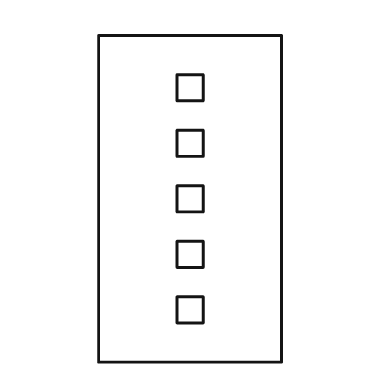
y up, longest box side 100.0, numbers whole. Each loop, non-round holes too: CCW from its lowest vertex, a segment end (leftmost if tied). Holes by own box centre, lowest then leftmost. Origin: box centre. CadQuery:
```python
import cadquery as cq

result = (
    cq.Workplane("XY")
    .moveTo(-28.0, -50.0)
    .lineTo(28.0, -50.0)
    .lineTo(28.0, 50.0)
    .lineTo(-28.0, 50.0)
    .close()
    .moveTo(-4.0, -38.0)
    .lineTo(4.0, -38.0)
    .lineTo(4.0, -30.0)
    .lineTo(-4.0, -30.0)
    .close()
    .moveTo(-4.0, -21.0)
    .lineTo(4.0, -21.0)
    .lineTo(4.0, -13.0)
    .lineTo(-4.0, -13.0)
    .close()
    .moveTo(-4.0, -4.0)
    .lineTo(4.0, -4.0)
    .lineTo(4.0, 4.0)
    .lineTo(-4.0, 4.0)
    .close()
    .moveTo(-4.0, 13.0)
    .lineTo(4.0, 13.0)
    .lineTo(4.0, 21.0)
    .lineTo(-4.0, 21.0)
    .close()
    .moveTo(-4.0, 30.0)
    .lineTo(4.0, 30.0)
    .lineTo(4.0, 38.0)
    .lineTo(-4.0, 38.0)
    .close()
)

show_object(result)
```